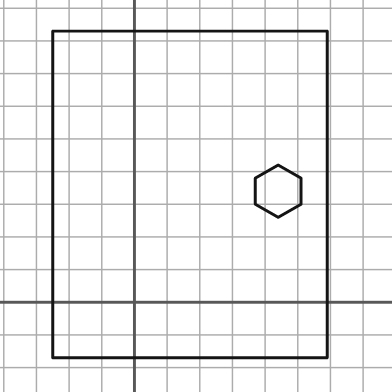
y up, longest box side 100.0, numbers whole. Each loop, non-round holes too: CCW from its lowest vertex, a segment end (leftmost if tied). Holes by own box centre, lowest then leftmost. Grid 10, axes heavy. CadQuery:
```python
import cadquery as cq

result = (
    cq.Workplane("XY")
    .moveTo(-25.0, -17.0)
    .lineTo(59.0, -17.0)
    .lineTo(59.0, 83.0)
    .lineTo(-25.0, 83.0)
    .close()
    .moveTo(44.0, 26.0)
    .lineTo(51.0, 30.0)
    .lineTo(51.0, 38.0)
    .lineTo(44.0, 42.0)
    .lineTo(37.0, 38.0)
    .lineTo(37.0, 30.0)
    .close()
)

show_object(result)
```